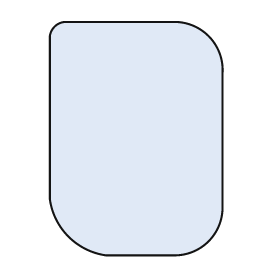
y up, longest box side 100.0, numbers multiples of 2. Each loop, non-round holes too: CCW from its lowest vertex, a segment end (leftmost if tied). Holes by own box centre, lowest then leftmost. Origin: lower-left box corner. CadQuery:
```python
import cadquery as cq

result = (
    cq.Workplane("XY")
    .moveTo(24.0, 0.0)
    .lineTo(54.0, 0.0)
    .threePointArc((68.0, 6.0), (74.0, 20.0))
    .lineTo(74.0, 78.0)
    .threePointArc((68.0, 94.0), (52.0, 100.0))
    .lineTo(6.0, 100.0)
    .threePointArc((2.0, 98.0), (0.0, 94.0))
    .lineTo(0.0, 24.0)
    .threePointArc((8.0, 8.0), (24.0, 0.0))
    .close()
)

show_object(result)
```